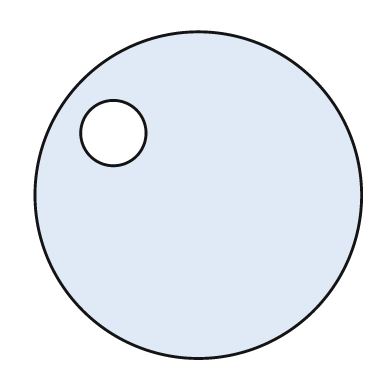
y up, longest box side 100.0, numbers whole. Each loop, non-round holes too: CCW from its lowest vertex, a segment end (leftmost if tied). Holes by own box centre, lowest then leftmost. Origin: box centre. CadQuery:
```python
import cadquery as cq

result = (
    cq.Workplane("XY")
    .moveTo(0.0, 0.0)
    .circle(50.0)
    .moveTo(-26.0, 19.0)
    .circle(10.0)
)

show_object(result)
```